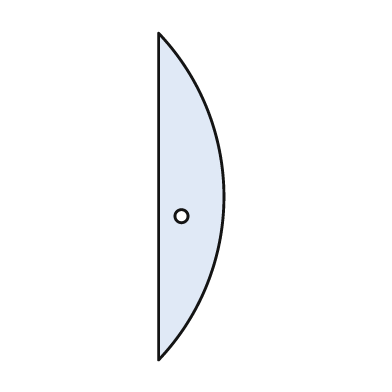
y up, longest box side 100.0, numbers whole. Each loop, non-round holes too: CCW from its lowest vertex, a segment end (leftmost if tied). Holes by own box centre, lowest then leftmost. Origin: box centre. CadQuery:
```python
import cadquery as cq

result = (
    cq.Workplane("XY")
    .moveTo(-10.0, -50.0)
    .threePointArc((10.0, 0.0), (-10.0, 50.0))
    .close()
    .moveTo(-3.0, -6.0)
    .circle(2.0)
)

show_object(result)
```